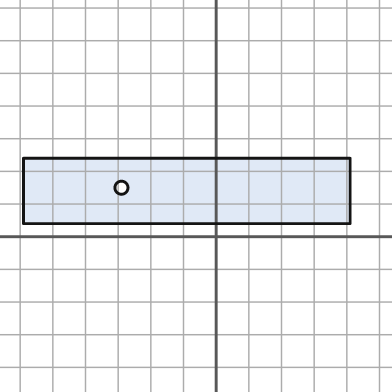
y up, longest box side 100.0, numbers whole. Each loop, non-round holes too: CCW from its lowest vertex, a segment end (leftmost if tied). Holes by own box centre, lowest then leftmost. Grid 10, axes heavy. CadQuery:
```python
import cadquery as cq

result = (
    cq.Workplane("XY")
    .moveTo(-59.0, 4.0)
    .lineTo(41.0, 4.0)
    .lineTo(41.0, 24.0)
    .lineTo(-59.0, 24.0)
    .close()
    .moveTo(-29.0, 15.0)
    .circle(2.0)
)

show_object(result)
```